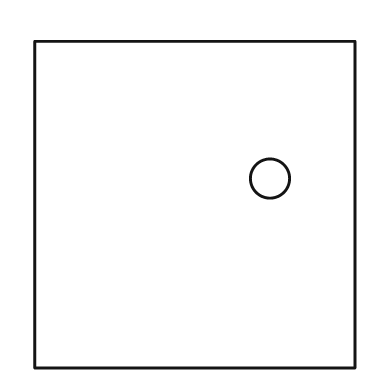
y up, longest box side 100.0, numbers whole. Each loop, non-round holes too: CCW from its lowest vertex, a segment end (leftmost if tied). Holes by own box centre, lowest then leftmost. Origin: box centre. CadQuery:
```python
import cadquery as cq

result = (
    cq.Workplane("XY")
    .moveTo(-49.0, -50.0)
    .lineTo(49.0, -50.0)
    .lineTo(49.0, 50.0)
    .lineTo(-49.0, 50.0)
    .close()
    .moveTo(23.0, 8.0)
    .circle(6.0)
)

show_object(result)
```